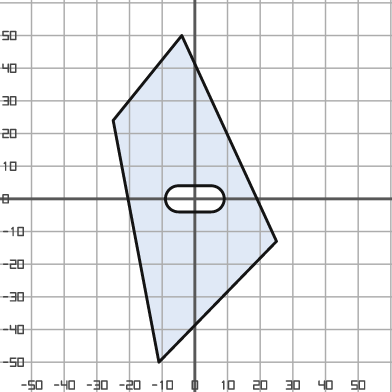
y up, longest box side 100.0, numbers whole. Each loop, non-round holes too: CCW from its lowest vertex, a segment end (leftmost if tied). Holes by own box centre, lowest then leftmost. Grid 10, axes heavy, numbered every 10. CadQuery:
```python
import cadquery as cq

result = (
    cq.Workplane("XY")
    .moveTo(-11.0, -50.0)
    .lineTo(25.0, -13.0)
    .lineTo(-4.0, 50.0)
    .lineTo(-25.0, 24.0)
    .close()
    .moveTo(-5.0, -4.0)
    .lineTo(5.0, -4.0)
    .threePointArc((9.0, 0.0), (5.0, 4.0))
    .lineTo(-5.0, 4.0)
    .threePointArc((-9.0, 0.0), (-5.0, -4.0))
    .close()
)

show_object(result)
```